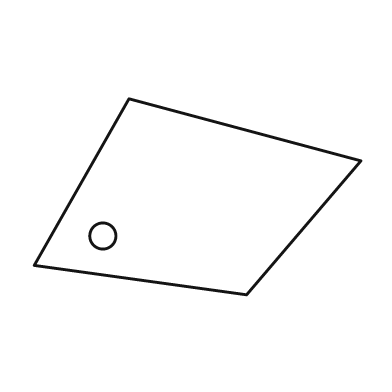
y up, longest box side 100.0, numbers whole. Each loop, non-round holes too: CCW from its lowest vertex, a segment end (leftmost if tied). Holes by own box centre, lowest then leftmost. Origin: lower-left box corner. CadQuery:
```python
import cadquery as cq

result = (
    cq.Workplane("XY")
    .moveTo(65.0, 0.0)
    .lineTo(100.0, 41.0)
    .lineTo(29.0, 60.0)
    .lineTo(0.0, 9.0)
    .close()
    .moveTo(21.0, 18.0)
    .circle(4.0)
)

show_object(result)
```